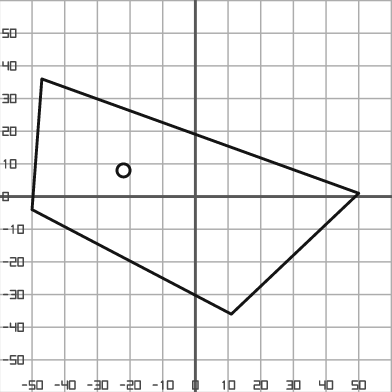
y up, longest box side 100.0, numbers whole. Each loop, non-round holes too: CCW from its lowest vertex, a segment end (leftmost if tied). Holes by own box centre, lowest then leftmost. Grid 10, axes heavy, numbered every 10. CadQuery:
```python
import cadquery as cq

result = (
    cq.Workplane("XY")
    .moveTo(11.0, -36.0)
    .lineTo(50.0, 1.0)
    .lineTo(-47.0, 36.0)
    .lineTo(-50.0, -4.0)
    .close()
    .moveTo(-22.0, 8.0)
    .circle(2.0)
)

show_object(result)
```